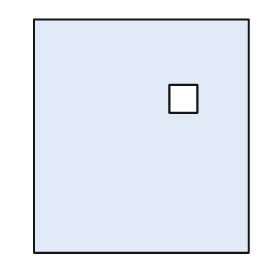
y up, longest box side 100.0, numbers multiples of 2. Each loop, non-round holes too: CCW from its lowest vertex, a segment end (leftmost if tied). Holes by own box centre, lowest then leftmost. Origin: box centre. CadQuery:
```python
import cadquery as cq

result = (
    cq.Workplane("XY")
    .moveTo(-46.0, -50.0)
    .lineTo(46.0, -50.0)
    .lineTo(46.0, 50.0)
    .lineTo(-46.0, 50.0)
    .close()
    .moveTo(12.0, 10.0)
    .lineTo(24.0, 10.0)
    .lineTo(24.0, 22.0)
    .lineTo(12.0, 22.0)
    .close()
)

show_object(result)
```